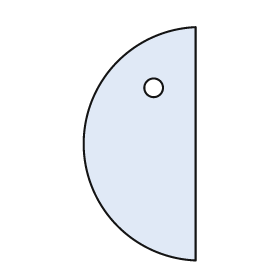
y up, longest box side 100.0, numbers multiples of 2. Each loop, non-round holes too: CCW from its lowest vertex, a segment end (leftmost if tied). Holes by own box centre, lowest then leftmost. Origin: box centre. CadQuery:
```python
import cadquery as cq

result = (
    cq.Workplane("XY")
    .moveTo(24.0, -50.0)
    .lineTo(24.0, 50.0)
    .threePointArc((-24.0, 0.0), (24.0, -50.0))
    .close()
    .moveTo(6.0, 24.0)
    .circle(4.0)
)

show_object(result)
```